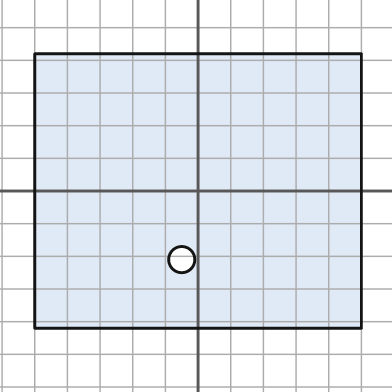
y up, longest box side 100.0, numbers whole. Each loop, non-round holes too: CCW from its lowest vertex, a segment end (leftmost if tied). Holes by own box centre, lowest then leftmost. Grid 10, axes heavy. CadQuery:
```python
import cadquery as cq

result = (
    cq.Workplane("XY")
    .moveTo(-50.0, -42.0)
    .lineTo(50.0, -42.0)
    .lineTo(50.0, 42.0)
    .lineTo(-50.0, 42.0)
    .close()
    .moveTo(-5.0, -21.0)
    .circle(4.0)
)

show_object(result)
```